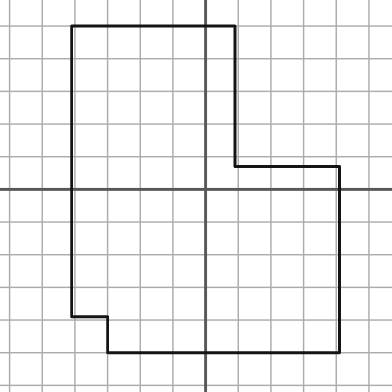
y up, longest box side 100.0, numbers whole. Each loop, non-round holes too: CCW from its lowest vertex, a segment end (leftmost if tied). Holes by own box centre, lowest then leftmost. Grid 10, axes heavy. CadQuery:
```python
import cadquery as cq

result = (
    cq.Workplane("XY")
    .moveTo(-30.0, -50.0)
    .lineTo(41.0, -50.0)
    .lineTo(41.0, 7.0)
    .lineTo(9.0, 7.0)
    .lineTo(9.0, 50.0)
    .lineTo(-41.0, 50.0)
    .lineTo(-41.0, -39.0)
    .lineTo(-30.0, -39.0)
    .close()
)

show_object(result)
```